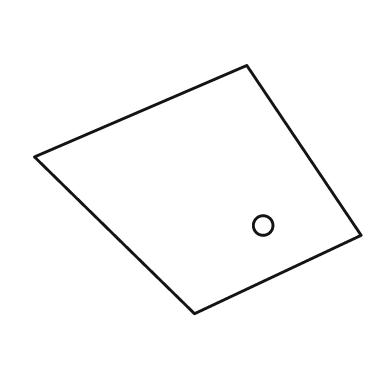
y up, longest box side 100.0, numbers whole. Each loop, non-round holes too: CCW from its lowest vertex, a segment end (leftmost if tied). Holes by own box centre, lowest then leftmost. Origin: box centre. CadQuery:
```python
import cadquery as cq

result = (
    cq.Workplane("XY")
    .moveTo(-1.0, -38.0)
    .lineTo(50.0, -14.0)
    .lineTo(15.0, 38.0)
    .lineTo(-50.0, 10.0)
    .close()
    .moveTo(20.0, -11.0)
    .circle(3.0)
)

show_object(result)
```